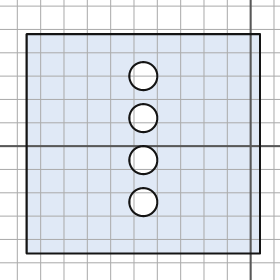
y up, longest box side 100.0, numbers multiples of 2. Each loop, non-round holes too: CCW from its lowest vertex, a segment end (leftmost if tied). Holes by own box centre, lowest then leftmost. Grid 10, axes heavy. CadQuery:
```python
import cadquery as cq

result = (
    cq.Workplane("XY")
    .moveTo(-96.0, -46.0)
    .lineTo(4.0, -46.0)
    .lineTo(4.0, 48.0)
    .lineTo(-96.0, 48.0)
    .close()
    .moveTo(-46.0, -24.0)
    .circle(6.0)
    .moveTo(-46.0, -6.0)
    .circle(6.0)
    .moveTo(-46.0, 12.0)
    .circle(6.0)
    .moveTo(-46.0, 30.0)
    .circle(6.0)
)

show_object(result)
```